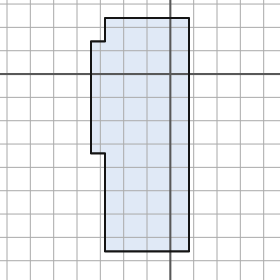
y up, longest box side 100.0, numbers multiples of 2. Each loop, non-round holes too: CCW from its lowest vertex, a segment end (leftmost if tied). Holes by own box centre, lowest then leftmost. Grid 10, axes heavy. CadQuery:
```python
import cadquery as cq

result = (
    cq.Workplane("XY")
    .moveTo(-28.0, -76.0)
    .lineTo(8.0, -76.0)
    .lineTo(8.0, 24.0)
    .lineTo(-28.0, 24.0)
    .lineTo(-28.0, 14.0)
    .lineTo(-34.0, 14.0)
    .lineTo(-34.0, -34.0)
    .lineTo(-28.0, -34.0)
    .close()
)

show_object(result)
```